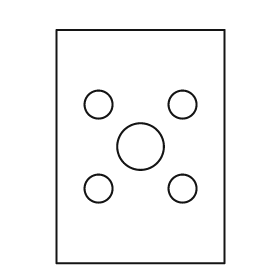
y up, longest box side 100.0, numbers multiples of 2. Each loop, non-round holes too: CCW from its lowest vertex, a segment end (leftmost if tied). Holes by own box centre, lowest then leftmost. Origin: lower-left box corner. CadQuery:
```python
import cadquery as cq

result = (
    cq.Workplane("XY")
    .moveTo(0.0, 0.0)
    .lineTo(72.0, 0.0)
    .lineTo(72.0, 100.0)
    .lineTo(0.0, 100.0)
    .close()
    .moveTo(18.0, 32.0)
    .circle(6.0)
    .moveTo(54.0, 32.0)
    .circle(6.0)
    .moveTo(36.0, 50.0)
    .circle(10.0)
    .moveTo(18.0, 68.0)
    .circle(6.0)
    .moveTo(54.0, 68.0)
    .circle(6.0)
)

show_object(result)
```